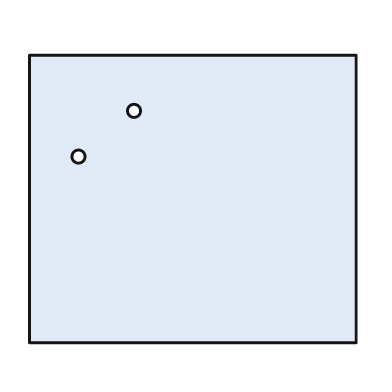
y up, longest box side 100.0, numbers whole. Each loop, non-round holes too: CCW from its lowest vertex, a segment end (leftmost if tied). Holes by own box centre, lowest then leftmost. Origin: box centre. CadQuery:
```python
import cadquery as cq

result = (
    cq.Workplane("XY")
    .moveTo(-50.0, -44.0)
    .lineTo(50.0, -44.0)
    .lineTo(50.0, 44.0)
    .lineTo(-50.0, 44.0)
    .close()
    .moveTo(-35.0, 13.0)
    .circle(2.0)
    .moveTo(-18.0, 27.0)
    .circle(2.0)
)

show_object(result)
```